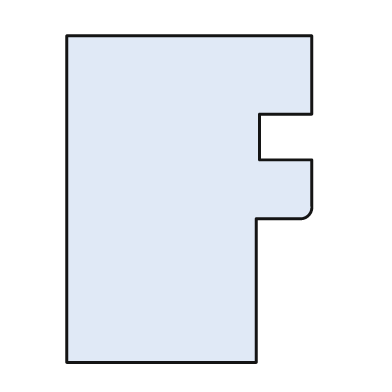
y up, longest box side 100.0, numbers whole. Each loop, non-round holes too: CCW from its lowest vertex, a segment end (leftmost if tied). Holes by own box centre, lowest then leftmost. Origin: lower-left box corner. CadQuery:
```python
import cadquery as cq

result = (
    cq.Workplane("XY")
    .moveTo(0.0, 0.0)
    .lineTo(58.0, 0.0)
    .lineTo(58.0, 44.0)
    .lineTo(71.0, 44.0)
    .threePointArc((74.0, 45.0), (75.0, 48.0))
    .lineTo(75.0, 62.0)
    .lineTo(59.0, 62.0)
    .lineTo(59.0, 76.0)
    .lineTo(75.0, 76.0)
    .lineTo(75.0, 100.0)
    .lineTo(0.0, 100.0)
    .close()
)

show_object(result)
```